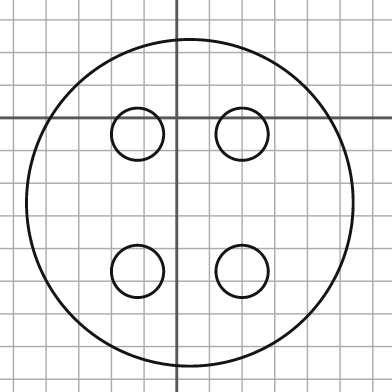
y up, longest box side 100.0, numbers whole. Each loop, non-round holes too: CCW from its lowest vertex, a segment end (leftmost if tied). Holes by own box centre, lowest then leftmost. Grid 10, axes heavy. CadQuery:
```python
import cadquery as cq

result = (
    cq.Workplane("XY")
    .moveTo(4.0, -26.0)
    .circle(50.0)
    .moveTo(-12.0, -47.0)
    .circle(8.0)
    .moveTo(20.0, -47.0)
    .circle(8.0)
    .moveTo(-12.0, -5.0)
    .circle(8.0)
    .moveTo(20.0, -5.0)
    .circle(8.0)
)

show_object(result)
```